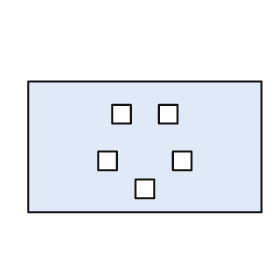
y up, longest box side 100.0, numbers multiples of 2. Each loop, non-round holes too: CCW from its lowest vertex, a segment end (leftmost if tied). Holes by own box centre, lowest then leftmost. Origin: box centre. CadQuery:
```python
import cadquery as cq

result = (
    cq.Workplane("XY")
    .moveTo(-50.0, -28.0)
    .lineTo(50.0, -28.0)
    .lineTo(50.0, 28.0)
    .lineTo(-50.0, 28.0)
    .close()
    .moveTo(-4.0, -22.0)
    .lineTo(4.0, -22.0)
    .lineTo(4.0, -14.0)
    .lineTo(-4.0, -14.0)
    .close()
    .moveTo(-20.0, -10.0)
    .lineTo(-12.0, -10.0)
    .lineTo(-12.0, -2.0)
    .lineTo(-20.0, -2.0)
    .close()
    .moveTo(12.0, -10.0)
    .lineTo(20.0, -10.0)
    .lineTo(20.0, -2.0)
    .lineTo(12.0, -2.0)
    .close()
    .moveTo(-14.0, 10.0)
    .lineTo(-6.0, 10.0)
    .lineTo(-6.0, 18.0)
    .lineTo(-14.0, 18.0)
    .close()
    .moveTo(6.0, 10.0)
    .lineTo(14.0, 10.0)
    .lineTo(14.0, 18.0)
    .lineTo(6.0, 18.0)
    .close()
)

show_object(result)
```